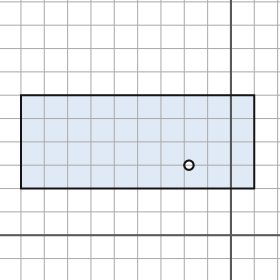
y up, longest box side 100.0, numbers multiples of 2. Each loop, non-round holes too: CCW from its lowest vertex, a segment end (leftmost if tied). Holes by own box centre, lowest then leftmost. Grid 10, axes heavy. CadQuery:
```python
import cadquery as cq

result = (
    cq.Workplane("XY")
    .moveTo(-90.0, 20.0)
    .lineTo(10.0, 20.0)
    .lineTo(10.0, 60.0)
    .lineTo(-90.0, 60.0)
    .close()
    .moveTo(-18.0, 30.0)
    .circle(2.0)
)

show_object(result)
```